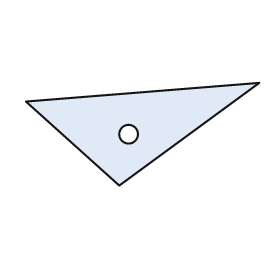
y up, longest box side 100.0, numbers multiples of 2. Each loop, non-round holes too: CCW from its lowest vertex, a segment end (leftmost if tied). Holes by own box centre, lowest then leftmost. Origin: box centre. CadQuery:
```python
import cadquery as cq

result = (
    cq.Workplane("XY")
    .moveTo(-10.0, -22.0)
    .lineTo(50.0, 22.0)
    .lineTo(-50.0, 14.0)
    .close()
    .moveTo(-6.0, 0.0)
    .circle(4.0)
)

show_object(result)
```